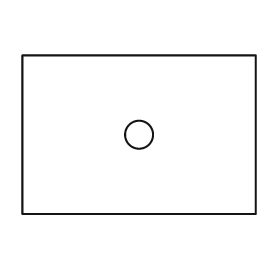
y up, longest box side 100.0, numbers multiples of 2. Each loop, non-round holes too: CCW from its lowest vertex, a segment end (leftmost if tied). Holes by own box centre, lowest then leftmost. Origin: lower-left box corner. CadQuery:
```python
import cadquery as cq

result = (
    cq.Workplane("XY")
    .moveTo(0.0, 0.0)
    .lineTo(100.0, 0.0)
    .lineTo(100.0, 68.0)
    .lineTo(0.0, 68.0)
    .close()
    .moveTo(50.0, 34.0)
    .circle(6.0)
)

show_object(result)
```